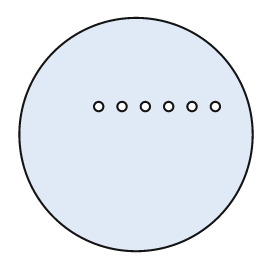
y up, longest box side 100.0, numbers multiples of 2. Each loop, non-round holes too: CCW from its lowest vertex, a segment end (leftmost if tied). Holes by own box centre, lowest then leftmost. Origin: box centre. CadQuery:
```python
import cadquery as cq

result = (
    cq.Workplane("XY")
    .moveTo(0.0, 0.0)
    .circle(50.0)
    .moveTo(-16.0, 12.0)
    .circle(2.0)
    .moveTo(-6.0, 12.0)
    .circle(2.0)
    .moveTo(4.0, 12.0)
    .circle(2.0)
    .moveTo(14.0, 12.0)
    .circle(2.0)
    .moveTo(24.0, 12.0)
    .circle(2.0)
    .moveTo(34.0, 12.0)
    .circle(2.0)
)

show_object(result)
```